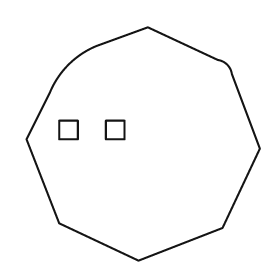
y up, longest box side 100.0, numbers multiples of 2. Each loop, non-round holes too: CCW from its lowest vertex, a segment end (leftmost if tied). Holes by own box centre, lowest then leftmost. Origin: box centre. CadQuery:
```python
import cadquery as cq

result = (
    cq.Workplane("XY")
    .moveTo(-2.0, -50.0)
    .lineTo(34.0, -36.0)
    .lineTo(50.0, -2.0)
    .lineTo(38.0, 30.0)
    .threePointArc((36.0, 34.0), (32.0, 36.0))
    .lineTo(2.0, 50.0)
    .lineTo(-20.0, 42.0)
    .threePointArc((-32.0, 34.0), (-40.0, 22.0))
    .lineTo(-50.0, 2.0)
    .lineTo(-36.0, -34.0)
    .close()
    .moveTo(-36.0, 2.0)
    .lineTo(-28.0, 2.0)
    .lineTo(-28.0, 10.0)
    .lineTo(-36.0, 10.0)
    .close()
    .moveTo(-16.0, 2.0)
    .lineTo(-8.0, 2.0)
    .lineTo(-8.0, 10.0)
    .lineTo(-16.0, 10.0)
    .close()
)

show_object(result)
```